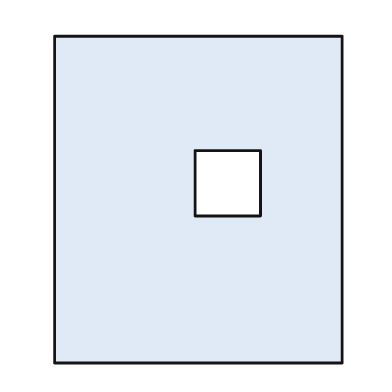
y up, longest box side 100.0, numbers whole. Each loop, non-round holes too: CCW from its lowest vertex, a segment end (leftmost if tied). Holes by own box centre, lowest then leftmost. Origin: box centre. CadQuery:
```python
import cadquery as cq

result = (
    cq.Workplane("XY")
    .moveTo(-44.0, -50.0)
    .lineTo(44.0, -50.0)
    .lineTo(44.0, 50.0)
    .lineTo(-44.0, 50.0)
    .close()
    .moveTo(-1.0, -5.0)
    .lineTo(19.0, -5.0)
    .lineTo(19.0, 15.0)
    .lineTo(-1.0, 15.0)
    .close()
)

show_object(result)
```